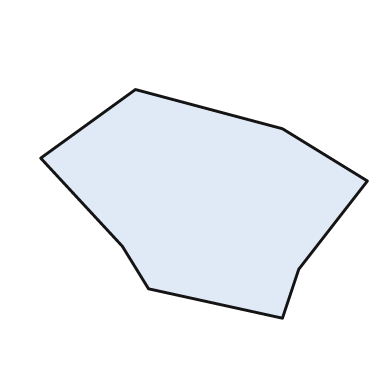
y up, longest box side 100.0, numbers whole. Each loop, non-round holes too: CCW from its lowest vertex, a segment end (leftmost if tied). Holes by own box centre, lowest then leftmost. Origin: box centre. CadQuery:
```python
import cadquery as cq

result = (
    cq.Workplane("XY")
    .moveTo(24.0, -35.0)
    .lineTo(29.0, -20.0)
    .lineTo(50.0, 7.0)
    .lineTo(24.0, 23.0)
    .lineTo(-21.0, 35.0)
    .lineTo(-50.0, 14.0)
    .lineTo(-25.0, -13.0)
    .lineTo(-17.0, -26.0)
    .close()
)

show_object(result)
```